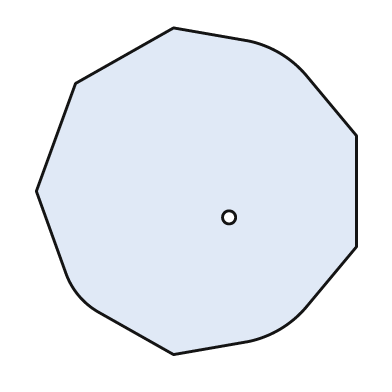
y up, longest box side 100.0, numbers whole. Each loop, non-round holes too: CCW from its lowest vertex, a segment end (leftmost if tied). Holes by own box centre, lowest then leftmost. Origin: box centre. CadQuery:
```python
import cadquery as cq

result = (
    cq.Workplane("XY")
    .moveTo(-7.0, -50.0)
    .lineTo(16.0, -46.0)
    .threePointArc((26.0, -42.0), (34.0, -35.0))
    .lineTo(49.0, -17.0)
    .lineTo(49.0, 17.0)
    .lineTo(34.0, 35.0)
    .threePointArc((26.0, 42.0), (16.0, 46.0))
    .lineTo(-7.0, 50.0)
    .lineTo(-37.0, 33.0)
    .lineTo(-49.0, 0.0)
    .lineTo(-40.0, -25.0)
    .threePointArc((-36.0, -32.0), (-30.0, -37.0))
    .close()
    .moveTo(10.0, -8.0)
    .circle(2.0)
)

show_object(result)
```